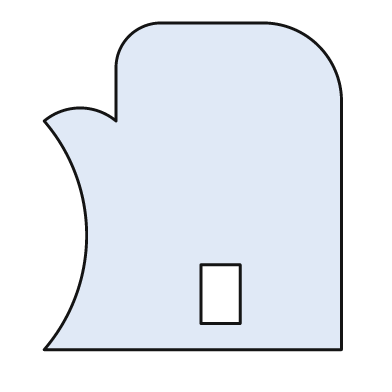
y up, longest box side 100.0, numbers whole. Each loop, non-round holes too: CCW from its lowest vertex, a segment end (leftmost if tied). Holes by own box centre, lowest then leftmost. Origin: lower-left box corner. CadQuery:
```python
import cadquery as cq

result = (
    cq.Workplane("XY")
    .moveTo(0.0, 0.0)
    .lineTo(91.0, 0.0)
    .lineTo(91.0, 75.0)
    .threePointArc((84.0, 93.0), (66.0, 100.0))
    .lineTo(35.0, 100.0)
    .threePointArc((26.0, 96.0), (22.0, 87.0))
    .lineTo(22.0, 70.0)
    .threePointArc((11.0, 74.0), (0.0, 70.0))
    .threePointArc((13.0, 35.0), (0.0, 0.0))
    .close()
    .moveTo(48.0, 8.0)
    .lineTo(60.0, 8.0)
    .lineTo(60.0, 26.0)
    .lineTo(48.0, 26.0)
    .close()
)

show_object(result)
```